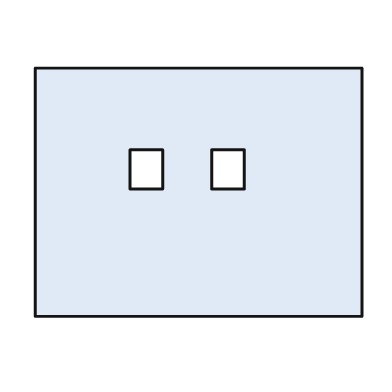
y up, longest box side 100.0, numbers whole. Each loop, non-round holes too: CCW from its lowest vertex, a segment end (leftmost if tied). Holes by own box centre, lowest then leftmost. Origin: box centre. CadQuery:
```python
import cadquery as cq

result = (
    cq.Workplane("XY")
    .moveTo(-50.0, -38.0)
    .lineTo(50.0, -38.0)
    .lineTo(50.0, 38.0)
    .lineTo(-50.0, 38.0)
    .close()
    .moveTo(-21.0, 1.0)
    .lineTo(-11.0, 1.0)
    .lineTo(-11.0, 13.0)
    .lineTo(-21.0, 13.0)
    .close()
    .moveTo(4.0, 1.0)
    .lineTo(14.0, 1.0)
    .lineTo(14.0, 13.0)
    .lineTo(4.0, 13.0)
    .close()
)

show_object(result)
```